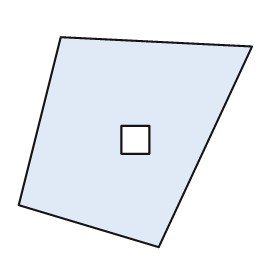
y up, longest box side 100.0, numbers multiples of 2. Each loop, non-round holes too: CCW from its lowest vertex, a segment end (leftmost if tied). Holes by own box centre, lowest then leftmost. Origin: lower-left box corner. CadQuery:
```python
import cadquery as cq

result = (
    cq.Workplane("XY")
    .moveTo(60.0, 0.0)
    .lineTo(100.0, 86.0)
    .lineTo(18.0, 90.0)
    .lineTo(0.0, 18.0)
    .close()
    .moveTo(44.0, 40.0)
    .lineTo(56.0, 40.0)
    .lineTo(56.0, 52.0)
    .lineTo(44.0, 52.0)
    .close()
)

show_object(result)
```